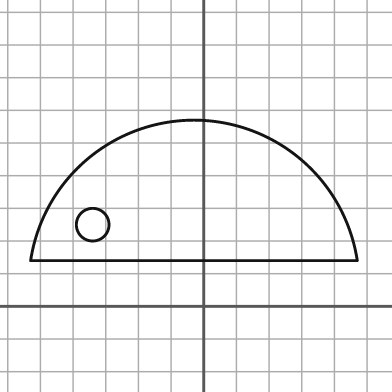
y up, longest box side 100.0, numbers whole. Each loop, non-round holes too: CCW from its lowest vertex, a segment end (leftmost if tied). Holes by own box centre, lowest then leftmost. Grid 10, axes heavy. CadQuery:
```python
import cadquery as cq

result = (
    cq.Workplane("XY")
    .moveTo(-53.0, 14.0)
    .lineTo(47.0, 14.0)
    .threePointArc((-3.0, 57.0), (-53.0, 14.0))
    .close()
    .moveTo(-34.0, 25.0)
    .circle(5.0)
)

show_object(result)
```